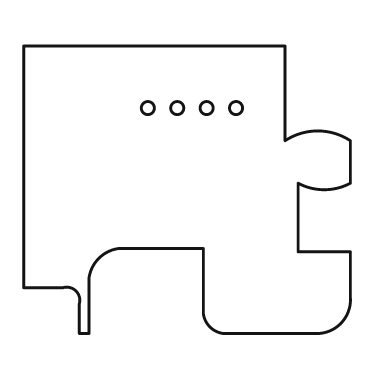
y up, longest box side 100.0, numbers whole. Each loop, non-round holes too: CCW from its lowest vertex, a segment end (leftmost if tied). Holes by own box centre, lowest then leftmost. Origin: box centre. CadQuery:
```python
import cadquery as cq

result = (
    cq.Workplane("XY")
    .moveTo(-33.0, -44.0)
    .lineTo(-30.0, -44.0)
    .lineTo(-30.0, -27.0)
    .threePointArc((-27.0, -21.0), (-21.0, -18.0))
    .lineTo(5.0, -18.0)
    .lineTo(5.0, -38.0)
    .threePointArc((7.0, -42.0), (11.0, -44.0))
    .lineTo(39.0, -44.0)
    .threePointArc((47.0, -41.0), (50.0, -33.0))
    .lineTo(50.0, -19.0)
    .lineTo(34.0, -19.0)
    .lineTo(34.0, 2.0)
    .threePointArc((42.0, 0.0), (50.0, 2.0))
    .lineTo(50.0, 15.0)
    .threePointArc((40.0, 18.0), (30.0, 15.0))
    .lineTo(30.0, 44.0)
    .lineTo(-50.0, 44.0)
    .lineTo(-50.0, -30.0)
    .lineTo(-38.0, -30.0)
    .threePointArc((-34.0, -31.0), (-33.0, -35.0))
    .close()
    .moveTo(-12.0, 25.0)
    .circle(2.0)
    .moveTo(-3.0, 25.0)
    .circle(2.0)
    .moveTo(6.0, 25.0)
    .circle(2.0)
    .moveTo(15.0, 25.0)
    .circle(2.0)
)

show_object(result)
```